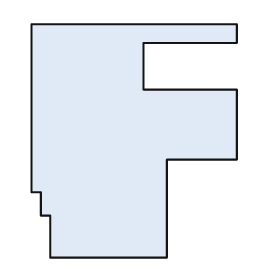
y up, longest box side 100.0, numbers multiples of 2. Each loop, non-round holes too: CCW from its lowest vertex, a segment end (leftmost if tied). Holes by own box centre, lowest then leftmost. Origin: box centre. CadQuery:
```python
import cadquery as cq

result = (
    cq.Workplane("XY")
    .moveTo(-36.0, -50.0)
    .lineTo(14.0, -50.0)
    .lineTo(14.0, -8.0)
    .lineTo(44.0, -8.0)
    .lineTo(44.0, 22.0)
    .lineTo(4.0, 22.0)
    .lineTo(4.0, 42.0)
    .lineTo(44.0, 42.0)
    .lineTo(44.0, 50.0)
    .lineTo(-44.0, 50.0)
    .lineTo(-44.0, -22.0)
    .lineTo(-40.0, -22.0)
    .lineTo(-40.0, -32.0)
    .lineTo(-36.0, -32.0)
    .close()
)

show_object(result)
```